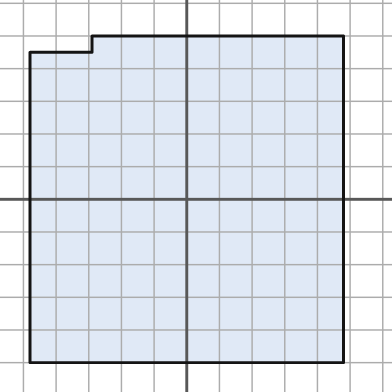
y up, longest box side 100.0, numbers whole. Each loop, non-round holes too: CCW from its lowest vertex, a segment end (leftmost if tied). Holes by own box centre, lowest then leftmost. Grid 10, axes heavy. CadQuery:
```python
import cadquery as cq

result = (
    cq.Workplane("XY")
    .moveTo(-48.0, -50.0)
    .lineTo(48.0, -50.0)
    .lineTo(48.0, 50.0)
    .lineTo(-29.0, 50.0)
    .lineTo(-29.0, 45.0)
    .lineTo(-48.0, 45.0)
    .close()
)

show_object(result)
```